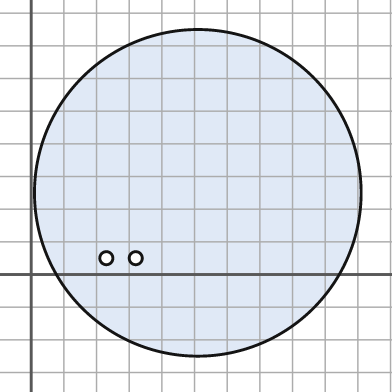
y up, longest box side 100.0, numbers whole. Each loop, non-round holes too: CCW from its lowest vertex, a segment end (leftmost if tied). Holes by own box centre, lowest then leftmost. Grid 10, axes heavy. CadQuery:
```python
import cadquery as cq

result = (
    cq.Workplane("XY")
    .moveTo(51.0, 25.0)
    .circle(50.0)
    .moveTo(23.0, 5.0)
    .circle(2.0)
    .moveTo(32.0, 5.0)
    .circle(2.0)
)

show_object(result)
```